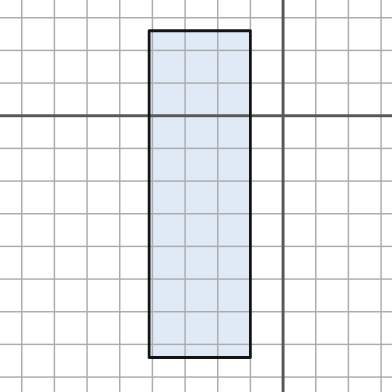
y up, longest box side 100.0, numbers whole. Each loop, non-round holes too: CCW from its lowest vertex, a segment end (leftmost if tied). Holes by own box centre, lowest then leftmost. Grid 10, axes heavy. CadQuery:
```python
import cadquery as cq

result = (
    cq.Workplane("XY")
    .moveTo(-41.0, -74.0)
    .lineTo(-10.0, -74.0)
    .lineTo(-10.0, 26.0)
    .lineTo(-41.0, 26.0)
    .close()
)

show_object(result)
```